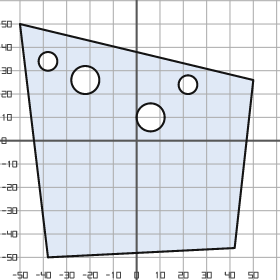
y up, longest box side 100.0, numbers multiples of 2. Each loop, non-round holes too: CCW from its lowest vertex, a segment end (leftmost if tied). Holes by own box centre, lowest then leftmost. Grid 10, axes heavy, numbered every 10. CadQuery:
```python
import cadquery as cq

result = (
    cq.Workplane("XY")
    .moveTo(-38.0, -50.0)
    .lineTo(42.0, -46.0)
    .lineTo(50.0, 26.0)
    .lineTo(-50.0, 50.0)
    .close()
    .moveTo(6.0, 10.0)
    .circle(6.0)
    .moveTo(22.0, 24.0)
    .circle(4.0)
    .moveTo(-22.0, 26.0)
    .circle(6.0)
    .moveTo(-38.0, 34.0)
    .circle(4.0)
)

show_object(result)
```